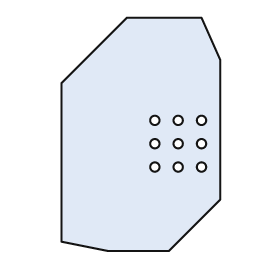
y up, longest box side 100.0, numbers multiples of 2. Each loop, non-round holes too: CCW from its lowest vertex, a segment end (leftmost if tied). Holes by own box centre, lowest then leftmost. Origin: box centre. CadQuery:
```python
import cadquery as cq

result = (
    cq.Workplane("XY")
    .moveTo(-14.0, -50.0)
    .lineTo(12.0, -50.0)
    .lineTo(34.0, -28.0)
    .lineTo(34.0, 32.0)
    .lineTo(26.0, 50.0)
    .lineTo(-6.0, 50.0)
    .lineTo(-34.0, 22.0)
    .lineTo(-34.0, -46.0)
    .close()
    .moveTo(6.0, -14.0)
    .circle(2.0)
    .moveTo(16.0, -14.0)
    .circle(2.0)
    .moveTo(26.0, -14.0)
    .circle(2.0)
    .moveTo(6.0, -4.0)
    .circle(2.0)
    .moveTo(16.0, -4.0)
    .circle(2.0)
    .moveTo(26.0, -4.0)
    .circle(2.0)
    .moveTo(6.0, 6.0)
    .circle(2.0)
    .moveTo(16.0, 6.0)
    .circle(2.0)
    .moveTo(26.0, 6.0)
    .circle(2.0)
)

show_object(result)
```